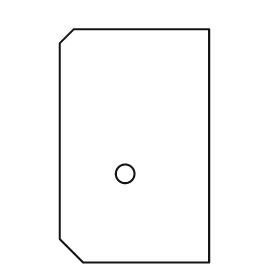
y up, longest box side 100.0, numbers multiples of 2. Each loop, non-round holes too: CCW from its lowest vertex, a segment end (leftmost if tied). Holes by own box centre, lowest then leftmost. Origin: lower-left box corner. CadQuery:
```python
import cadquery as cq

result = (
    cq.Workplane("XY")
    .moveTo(10.0, 0.0)
    .lineTo(64.0, 0.0)
    .lineTo(64.0, 100.0)
    .lineTo(6.0, 100.0)
    .lineTo(0.0, 94.0)
    .lineTo(0.0, 10.0)
    .close()
    .moveTo(28.0, 38.0)
    .circle(4.0)
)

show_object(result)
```